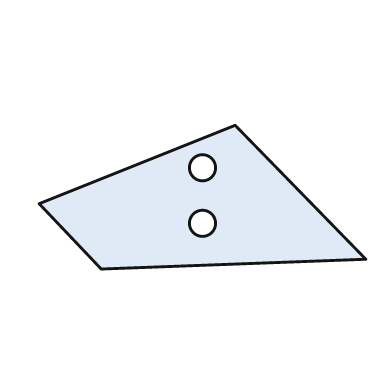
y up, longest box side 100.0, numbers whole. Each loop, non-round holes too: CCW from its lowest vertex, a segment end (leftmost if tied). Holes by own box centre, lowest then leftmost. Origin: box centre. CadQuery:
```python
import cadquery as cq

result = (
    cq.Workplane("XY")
    .moveTo(-31.0, -22.0)
    .lineTo(50.0, -19.0)
    .lineTo(10.0, 22.0)
    .lineTo(-50.0, -2.0)
    .close()
    .moveTo(0.0, -8.0)
    .circle(4.0)
    .moveTo(0.0, 9.0)
    .circle(4.0)
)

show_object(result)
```